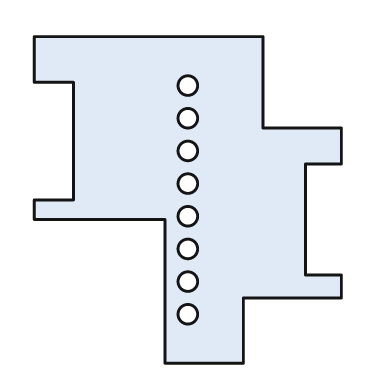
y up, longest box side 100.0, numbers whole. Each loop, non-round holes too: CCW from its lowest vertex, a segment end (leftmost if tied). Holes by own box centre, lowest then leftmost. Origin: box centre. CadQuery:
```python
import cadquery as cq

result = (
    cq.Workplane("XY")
    .moveTo(-7.0, -50.0)
    .lineTo(17.0, -50.0)
    .lineTo(17.0, -30.0)
    .lineTo(47.0, -30.0)
    .lineTo(47.0, -23.0)
    .lineTo(36.0, -23.0)
    .lineTo(36.0, 11.0)
    .lineTo(47.0, 11.0)
    .lineTo(47.0, 22.0)
    .lineTo(23.0, 22.0)
    .lineTo(23.0, 50.0)
    .lineTo(-47.0, 50.0)
    .lineTo(-47.0, 36.0)
    .lineTo(-35.0, 36.0)
    .lineTo(-35.0, 0.0)
    .lineTo(-47.0, 0.0)
    .lineTo(-47.0, -6.0)
    .lineTo(-7.0, -6.0)
    .close()
    .moveTo(0.0, -35.0)
    .circle(3.0)
    .moveTo(0.0, -25.0)
    .circle(3.0)
    .moveTo(0.0, -15.0)
    .circle(3.0)
    .moveTo(0.0, -5.0)
    .circle(3.0)
    .moveTo(0.0, 5.0)
    .circle(3.0)
    .moveTo(0.0, 15.0)
    .circle(3.0)
    .moveTo(0.0, 25.0)
    .circle(3.0)
    .moveTo(0.0, 35.0)
    .circle(3.0)
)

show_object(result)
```